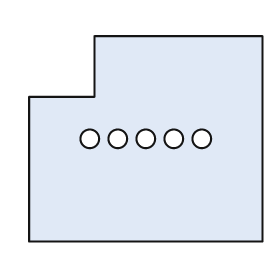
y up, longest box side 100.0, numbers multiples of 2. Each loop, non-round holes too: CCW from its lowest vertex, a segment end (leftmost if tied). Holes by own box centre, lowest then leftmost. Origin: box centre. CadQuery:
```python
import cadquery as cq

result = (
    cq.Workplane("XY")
    .moveTo(-50.0, -44.0)
    .lineTo(50.0, -44.0)
    .lineTo(50.0, 44.0)
    .lineTo(-22.0, 44.0)
    .lineTo(-22.0, 18.0)
    .lineTo(-50.0, 18.0)
    .close()
    .moveTo(-24.0, 0.0)
    .circle(4.0)
    .moveTo(-12.0, 0.0)
    .circle(4.0)
    .moveTo(0.0, 0.0)
    .circle(4.0)
    .moveTo(12.0, 0.0)
    .circle(4.0)
    .moveTo(24.0, 0.0)
    .circle(4.0)
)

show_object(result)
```